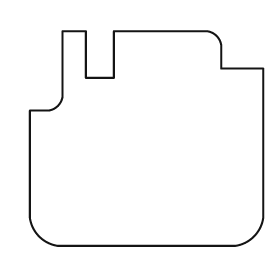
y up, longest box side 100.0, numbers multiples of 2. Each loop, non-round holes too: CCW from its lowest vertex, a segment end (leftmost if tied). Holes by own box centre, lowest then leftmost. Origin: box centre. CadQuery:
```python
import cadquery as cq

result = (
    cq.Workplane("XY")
    .moveTo(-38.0, -46.0)
    .lineTo(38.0, -46.0)
    .threePointArc((46.0, -42.0), (50.0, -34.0))
    .lineTo(50.0, 30.0)
    .lineTo(32.0, 30.0)
    .lineTo(32.0, 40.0)
    .threePointArc((30.0, 44.0), (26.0, 46.0))
    .lineTo(-14.0, 46.0)
    .lineTo(-14.0, 26.0)
    .lineTo(-26.0, 26.0)
    .lineTo(-26.0, 46.0)
    .lineTo(-36.0, 46.0)
    .lineTo(-36.0, 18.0)
    .threePointArc((-38.0, 14.0), (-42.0, 12.0))
    .lineTo(-50.0, 12.0)
    .lineTo(-50.0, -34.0)
    .threePointArc((-46.0, -42.0), (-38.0, -46.0))
    .close()
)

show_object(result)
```